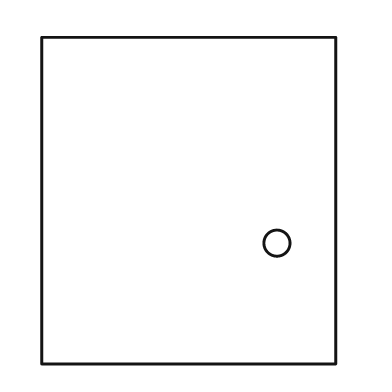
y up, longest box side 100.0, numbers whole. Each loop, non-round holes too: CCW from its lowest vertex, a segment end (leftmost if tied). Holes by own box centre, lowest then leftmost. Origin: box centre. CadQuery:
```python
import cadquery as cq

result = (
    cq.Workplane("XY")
    .moveTo(-45.0, -50.0)
    .lineTo(45.0, -50.0)
    .lineTo(45.0, 50.0)
    .lineTo(-45.0, 50.0)
    .close()
    .moveTo(27.0, -13.0)
    .circle(4.0)
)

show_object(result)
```